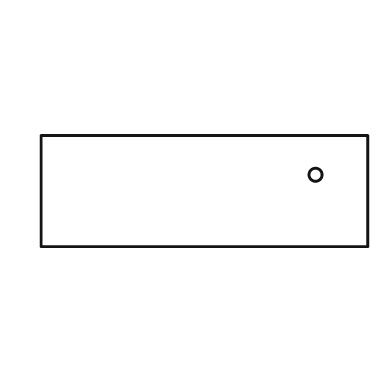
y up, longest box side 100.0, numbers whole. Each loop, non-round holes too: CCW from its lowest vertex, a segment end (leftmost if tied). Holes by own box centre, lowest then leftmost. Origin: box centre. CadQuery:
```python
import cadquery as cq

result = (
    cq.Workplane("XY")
    .moveTo(-50.0, -17.0)
    .lineTo(50.0, -17.0)
    .lineTo(50.0, 17.0)
    .lineTo(-50.0, 17.0)
    .close()
    .moveTo(34.0, 5.0)
    .circle(2.0)
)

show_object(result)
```